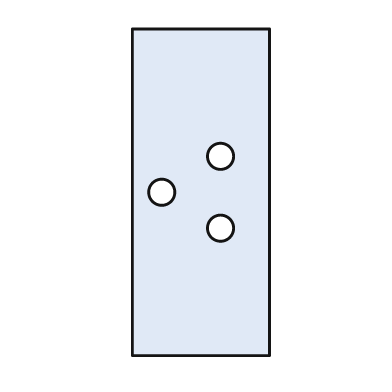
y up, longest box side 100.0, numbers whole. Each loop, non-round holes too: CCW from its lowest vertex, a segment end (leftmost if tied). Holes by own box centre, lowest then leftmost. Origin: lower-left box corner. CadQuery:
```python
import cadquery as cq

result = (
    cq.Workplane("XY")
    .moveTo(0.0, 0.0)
    .lineTo(42.0, 0.0)
    .lineTo(42.0, 100.0)
    .lineTo(0.0, 100.0)
    .close()
    .moveTo(27.0, 39.0)
    .circle(4.0)
    .moveTo(9.0, 50.0)
    .circle(4.0)
    .moveTo(27.0, 61.0)
    .circle(4.0)
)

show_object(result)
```